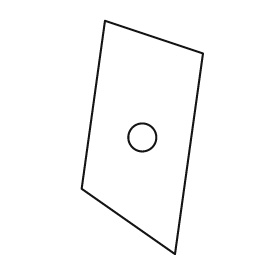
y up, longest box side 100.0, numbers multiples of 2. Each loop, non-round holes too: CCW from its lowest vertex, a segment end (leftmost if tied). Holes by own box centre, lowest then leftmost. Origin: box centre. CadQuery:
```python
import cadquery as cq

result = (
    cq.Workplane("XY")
    .moveTo(14.0, -50.0)
    .lineTo(26.0, 36.0)
    .lineTo(-16.0, 50.0)
    .lineTo(-26.0, -22.0)
    .close()
    .moveTo(0.0, 0.0)
    .circle(6.0)
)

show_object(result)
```